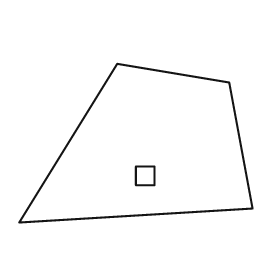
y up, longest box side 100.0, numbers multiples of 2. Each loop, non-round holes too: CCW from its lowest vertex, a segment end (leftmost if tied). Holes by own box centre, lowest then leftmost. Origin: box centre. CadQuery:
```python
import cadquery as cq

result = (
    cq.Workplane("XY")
    .moveTo(-50.0, -34.0)
    .lineTo(50.0, -28.0)
    .lineTo(40.0, 26.0)
    .lineTo(-8.0, 34.0)
    .close()
    .moveTo(0.0, -18.0)
    .lineTo(8.0, -18.0)
    .lineTo(8.0, -10.0)
    .lineTo(0.0, -10.0)
    .close()
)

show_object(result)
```